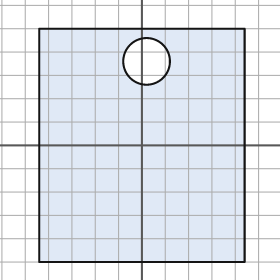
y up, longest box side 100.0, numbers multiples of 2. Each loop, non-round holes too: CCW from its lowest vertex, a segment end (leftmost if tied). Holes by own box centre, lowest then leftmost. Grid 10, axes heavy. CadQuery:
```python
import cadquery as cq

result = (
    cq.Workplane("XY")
    .moveTo(-44.0, -50.0)
    .lineTo(44.0, -50.0)
    .lineTo(44.0, 50.0)
    .lineTo(-44.0, 50.0)
    .close()
    .moveTo(2.0, 36.0)
    .circle(10.0)
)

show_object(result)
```